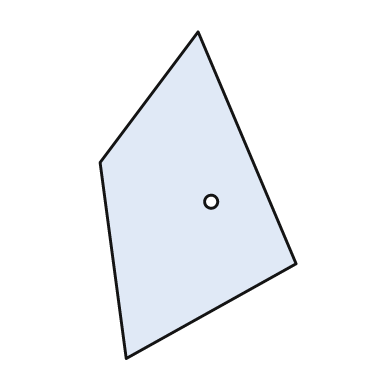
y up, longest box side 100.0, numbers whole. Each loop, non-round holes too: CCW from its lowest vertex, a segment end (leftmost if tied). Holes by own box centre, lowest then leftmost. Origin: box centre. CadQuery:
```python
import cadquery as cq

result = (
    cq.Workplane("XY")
    .moveTo(-22.0, -50.0)
    .lineTo(30.0, -21.0)
    .lineTo(0.0, 50.0)
    .lineTo(-30.0, 10.0)
    .close()
    .moveTo(4.0, -2.0)
    .circle(2.0)
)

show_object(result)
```